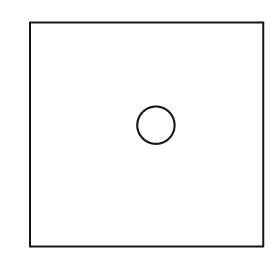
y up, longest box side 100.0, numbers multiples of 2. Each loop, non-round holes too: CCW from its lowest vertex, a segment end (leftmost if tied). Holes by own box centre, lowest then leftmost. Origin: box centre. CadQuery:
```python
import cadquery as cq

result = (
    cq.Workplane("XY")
    .moveTo(-50.0, -48.0)
    .lineTo(50.0, -48.0)
    .lineTo(50.0, 48.0)
    .lineTo(-50.0, 48.0)
    .close()
    .moveTo(4.0, 4.0)
    .circle(8.0)
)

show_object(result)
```